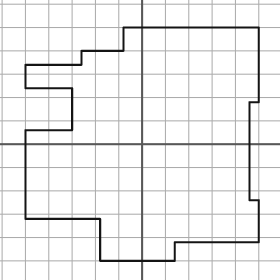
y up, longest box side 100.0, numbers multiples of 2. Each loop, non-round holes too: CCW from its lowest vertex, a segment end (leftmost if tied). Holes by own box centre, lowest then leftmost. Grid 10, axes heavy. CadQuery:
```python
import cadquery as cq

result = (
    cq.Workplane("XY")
    .moveTo(-18.0, -50.0)
    .lineTo(14.0, -50.0)
    .lineTo(14.0, -42.0)
    .lineTo(50.0, -42.0)
    .lineTo(50.0, -24.0)
    .lineTo(46.0, -24.0)
    .lineTo(46.0, 18.0)
    .lineTo(50.0, 18.0)
    .lineTo(50.0, 50.0)
    .lineTo(-8.0, 50.0)
    .lineTo(-8.0, 40.0)
    .lineTo(-26.0, 40.0)
    .lineTo(-26.0, 34.0)
    .lineTo(-50.0, 34.0)
    .lineTo(-50.0, 24.0)
    .lineTo(-30.0, 24.0)
    .lineTo(-30.0, 6.0)
    .lineTo(-50.0, 6.0)
    .lineTo(-50.0, -32.0)
    .lineTo(-18.0, -32.0)
    .close()
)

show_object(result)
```